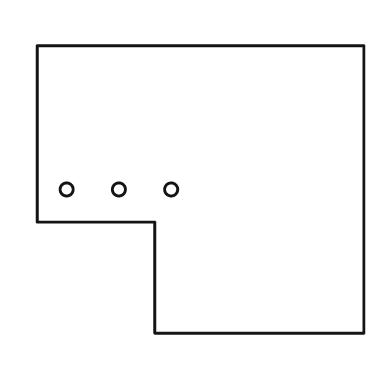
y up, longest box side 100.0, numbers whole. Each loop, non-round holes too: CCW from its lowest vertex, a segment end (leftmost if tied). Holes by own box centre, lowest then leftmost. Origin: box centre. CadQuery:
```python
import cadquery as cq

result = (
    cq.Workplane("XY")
    .moveTo(-14.0, -44.0)
    .lineTo(50.0, -44.0)
    .lineTo(50.0, 44.0)
    .lineTo(-50.0, 44.0)
    .lineTo(-50.0, -10.0)
    .lineTo(-14.0, -10.0)
    .close()
    .moveTo(-41.0, 0.0)
    .circle(2.0)
    .moveTo(-25.0, 0.0)
    .circle(2.0)
    .moveTo(-9.0, 0.0)
    .circle(2.0)
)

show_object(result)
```